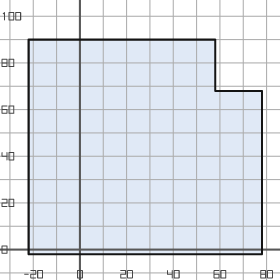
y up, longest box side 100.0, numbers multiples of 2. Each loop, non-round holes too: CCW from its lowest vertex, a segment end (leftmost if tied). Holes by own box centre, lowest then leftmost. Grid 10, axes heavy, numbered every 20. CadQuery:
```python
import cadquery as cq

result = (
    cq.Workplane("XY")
    .moveTo(-22.0, -2.0)
    .lineTo(78.0, -2.0)
    .lineTo(78.0, 68.0)
    .lineTo(58.0, 68.0)
    .lineTo(58.0, 90.0)
    .lineTo(-22.0, 90.0)
    .close()
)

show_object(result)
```